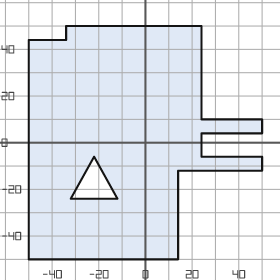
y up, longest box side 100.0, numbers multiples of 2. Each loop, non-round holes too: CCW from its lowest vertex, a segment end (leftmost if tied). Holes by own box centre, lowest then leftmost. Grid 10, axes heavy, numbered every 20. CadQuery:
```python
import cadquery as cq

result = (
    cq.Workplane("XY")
    .moveTo(-50.0, -50.0)
    .lineTo(14.0, -50.0)
    .lineTo(14.0, -12.0)
    .lineTo(50.0, -12.0)
    .lineTo(50.0, -6.0)
    .lineTo(24.0, -6.0)
    .lineTo(24.0, 4.0)
    .lineTo(50.0, 4.0)
    .lineTo(50.0, 10.0)
    .lineTo(24.0, 10.0)
    .lineTo(24.0, 50.0)
    .lineTo(-34.0, 50.0)
    .lineTo(-34.0, 44.0)
    .lineTo(-50.0, 44.0)
    .close()
    .moveTo(-32.0, -24.0)
    .lineTo(-12.0, -24.0)
    .lineTo(-22.0, -6.0)
    .close()
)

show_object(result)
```